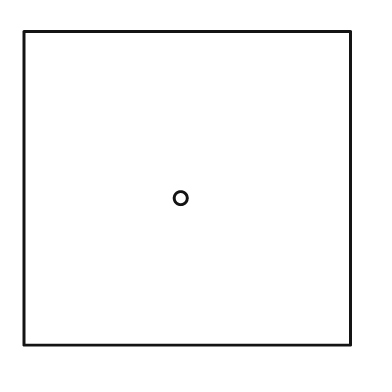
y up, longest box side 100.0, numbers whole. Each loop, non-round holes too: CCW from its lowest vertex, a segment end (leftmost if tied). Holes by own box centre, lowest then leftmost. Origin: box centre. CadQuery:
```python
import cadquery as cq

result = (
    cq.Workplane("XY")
    .moveTo(-50.0, -48.0)
    .lineTo(50.0, -48.0)
    .lineTo(50.0, 48.0)
    .lineTo(-50.0, 48.0)
    .close()
    .moveTo(-2.0, -3.0)
    .circle(2.0)
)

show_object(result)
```